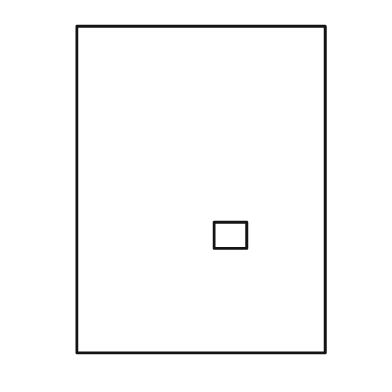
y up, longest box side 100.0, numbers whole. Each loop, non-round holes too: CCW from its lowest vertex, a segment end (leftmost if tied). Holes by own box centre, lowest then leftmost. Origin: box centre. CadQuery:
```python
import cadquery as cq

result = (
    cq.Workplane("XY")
    .moveTo(-38.0, -50.0)
    .lineTo(38.0, -50.0)
    .lineTo(38.0, 50.0)
    .lineTo(-38.0, 50.0)
    .close()
    .moveTo(4.0, -18.0)
    .lineTo(14.0, -18.0)
    .lineTo(14.0, -10.0)
    .lineTo(4.0, -10.0)
    .close()
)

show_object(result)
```